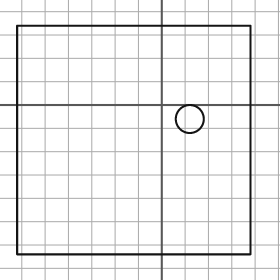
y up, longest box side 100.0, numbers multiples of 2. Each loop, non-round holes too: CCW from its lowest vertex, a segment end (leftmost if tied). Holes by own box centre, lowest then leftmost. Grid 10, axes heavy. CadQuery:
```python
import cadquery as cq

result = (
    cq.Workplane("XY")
    .moveTo(-62.0, -64.0)
    .lineTo(38.0, -64.0)
    .lineTo(38.0, 34.0)
    .lineTo(-62.0, 34.0)
    .close()
    .moveTo(12.0, -6.0)
    .circle(6.0)
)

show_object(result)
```